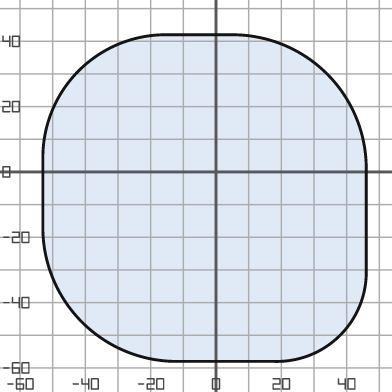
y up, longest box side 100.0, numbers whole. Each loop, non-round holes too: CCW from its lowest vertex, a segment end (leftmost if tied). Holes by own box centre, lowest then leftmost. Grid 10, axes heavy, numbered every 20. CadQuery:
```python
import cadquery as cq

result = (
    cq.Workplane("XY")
    .moveTo(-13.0, -58.0)
    .lineTo(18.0, -58.0)
    .threePointArc((38.0, -50.0), (46.0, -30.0))
    .lineTo(46.0, 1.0)
    .threePointArc((34.0, 30.0), (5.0, 42.0))
    .lineTo(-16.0, 42.0)
    .threePointArc((-42.0, 31.0), (-53.0, 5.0))
    .lineTo(-53.0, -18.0)
    .threePointArc((-41.0, -46.0), (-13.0, -58.0))
    .close()
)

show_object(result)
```